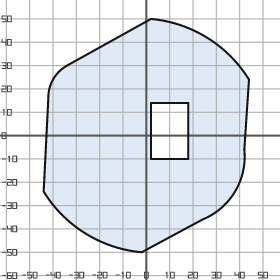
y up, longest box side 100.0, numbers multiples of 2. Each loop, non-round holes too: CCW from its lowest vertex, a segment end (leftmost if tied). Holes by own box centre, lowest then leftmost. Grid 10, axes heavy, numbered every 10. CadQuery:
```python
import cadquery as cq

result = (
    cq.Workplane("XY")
    .moveTo(-2.0, -50.0)
    .lineTo(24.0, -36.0)
    .threePointArc((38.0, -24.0), (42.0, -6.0))
    .lineTo(44.0, 24.0)
    .threePointArc((26.0, 42.0), (2.0, 50.0))
    .lineTo(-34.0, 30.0)
    .threePointArc((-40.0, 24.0), (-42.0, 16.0))
    .lineTo(-44.0, -24.0)
    .threePointArc((-26.0, -42.0), (-2.0, -50.0))
    .close()
    .moveTo(2.0, -10.0)
    .lineTo(18.0, -10.0)
    .lineTo(18.0, 14.0)
    .lineTo(2.0, 14.0)
    .close()
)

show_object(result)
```